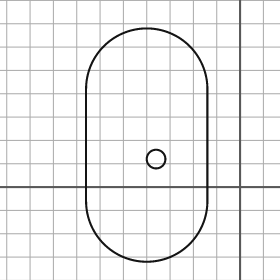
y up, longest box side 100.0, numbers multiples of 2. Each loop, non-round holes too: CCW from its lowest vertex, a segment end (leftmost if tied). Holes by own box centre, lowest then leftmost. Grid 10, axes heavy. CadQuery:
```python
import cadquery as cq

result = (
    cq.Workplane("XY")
    .moveTo(-66.0, -6.0)
    .threePointArc((-40.0, -32.0), (-14.0, -6.0))
    .lineTo(-14.0, 42.0)
    .threePointArc((-40.0, 68.0), (-66.0, 42.0))
    .close()
    .moveTo(-36.0, 12.0)
    .circle(4.0)
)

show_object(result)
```